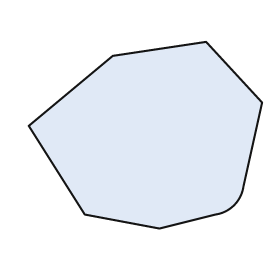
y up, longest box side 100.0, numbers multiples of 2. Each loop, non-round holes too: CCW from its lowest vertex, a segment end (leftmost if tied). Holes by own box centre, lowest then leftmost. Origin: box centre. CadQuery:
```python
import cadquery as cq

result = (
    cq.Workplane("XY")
    .moveTo(6.0, -40.0)
    .lineTo(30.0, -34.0)
    .threePointArc((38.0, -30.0), (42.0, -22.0))
    .lineTo(50.0, 14.0)
    .lineTo(26.0, 40.0)
    .lineTo(-14.0, 34.0)
    .lineTo(-50.0, 4.0)
    .lineTo(-26.0, -34.0)
    .close()
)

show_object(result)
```